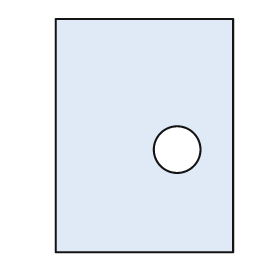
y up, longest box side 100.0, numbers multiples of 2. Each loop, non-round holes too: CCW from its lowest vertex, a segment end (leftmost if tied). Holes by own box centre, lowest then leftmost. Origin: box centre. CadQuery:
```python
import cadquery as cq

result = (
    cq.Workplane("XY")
    .moveTo(-38.0, -50.0)
    .lineTo(38.0, -50.0)
    .lineTo(38.0, 50.0)
    .lineTo(-38.0, 50.0)
    .close()
    .moveTo(14.0, -6.0)
    .circle(10.0)
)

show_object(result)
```